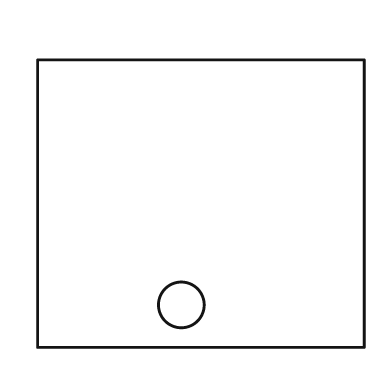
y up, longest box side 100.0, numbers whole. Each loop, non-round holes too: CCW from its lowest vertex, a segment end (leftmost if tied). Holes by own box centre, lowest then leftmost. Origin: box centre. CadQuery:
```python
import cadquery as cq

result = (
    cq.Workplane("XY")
    .moveTo(-50.0, -44.0)
    .lineTo(50.0, -44.0)
    .lineTo(50.0, 44.0)
    .lineTo(-50.0, 44.0)
    .close()
    .moveTo(-6.0, -31.0)
    .circle(7.0)
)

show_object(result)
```